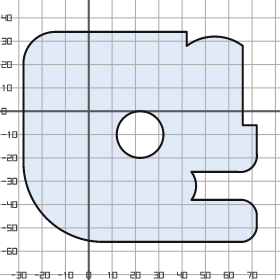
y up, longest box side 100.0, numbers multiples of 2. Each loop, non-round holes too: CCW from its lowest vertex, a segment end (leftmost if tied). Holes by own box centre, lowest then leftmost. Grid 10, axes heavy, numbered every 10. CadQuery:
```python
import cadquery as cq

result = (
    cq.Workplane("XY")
    .moveTo(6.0, -56.0)
    .lineTo(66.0, -56.0)
    .threePointArc((70.0, -54.0), (72.0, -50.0))
    .lineTo(72.0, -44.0)
    .threePointArc((70.0, -40.0), (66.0, -38.0))
    .lineTo(44.0, -38.0)
    .threePointArc((46.0, -32.0), (44.0, -26.0))
    .lineTo(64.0, -26.0)
    .threePointArc((70.0, -24.0), (72.0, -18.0))
    .lineTo(72.0, -6.0)
    .lineTo(66.0, -6.0)
    .lineTo(66.0, 28.0)
    .threePointArc((54.0, 32.0), (42.0, 28.0))
    .lineTo(42.0, 34.0)
    .lineTo(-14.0, 34.0)
    .threePointArc((-24.0, 30.0), (-28.0, 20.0))
    .lineTo(-28.0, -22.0)
    .threePointArc((-18.0, -46.0), (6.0, -56.0))
    .close()
    .moveTo(22.0, -10.0)
    .circle(10.0)
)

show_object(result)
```